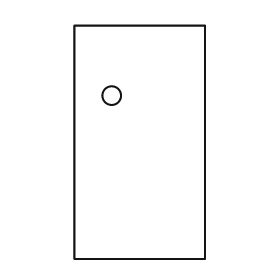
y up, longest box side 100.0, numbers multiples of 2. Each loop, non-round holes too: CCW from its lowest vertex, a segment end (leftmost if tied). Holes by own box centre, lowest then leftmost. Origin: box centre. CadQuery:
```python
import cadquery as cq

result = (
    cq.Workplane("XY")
    .moveTo(-28.0, -50.0)
    .lineTo(28.0, -50.0)
    .lineTo(28.0, 50.0)
    .lineTo(-28.0, 50.0)
    .close()
    .moveTo(-12.0, 20.0)
    .circle(4.0)
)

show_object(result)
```